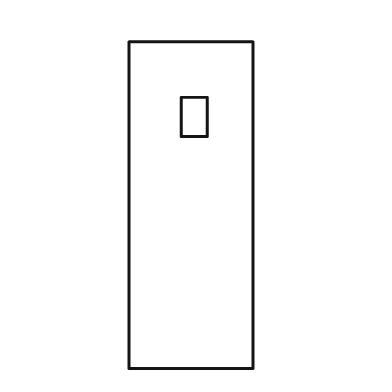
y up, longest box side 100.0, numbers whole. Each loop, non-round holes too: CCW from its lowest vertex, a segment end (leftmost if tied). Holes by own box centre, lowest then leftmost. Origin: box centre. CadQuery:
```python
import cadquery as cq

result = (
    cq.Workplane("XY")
    .moveTo(-19.0, -50.0)
    .lineTo(19.0, -50.0)
    .lineTo(19.0, 50.0)
    .lineTo(-19.0, 50.0)
    .close()
    .moveTo(-3.0, 21.0)
    .lineTo(5.0, 21.0)
    .lineTo(5.0, 33.0)
    .lineTo(-3.0, 33.0)
    .close()
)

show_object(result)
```